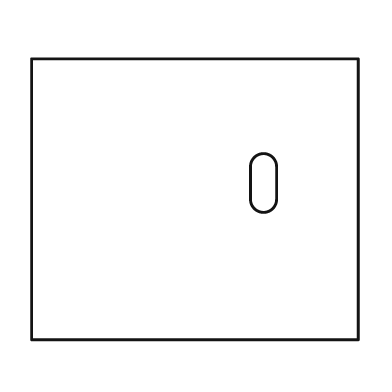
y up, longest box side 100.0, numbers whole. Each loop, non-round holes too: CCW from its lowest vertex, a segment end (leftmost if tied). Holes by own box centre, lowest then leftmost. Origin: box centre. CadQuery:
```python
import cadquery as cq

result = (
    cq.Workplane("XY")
    .moveTo(-50.0, -43.0)
    .lineTo(50.0, -43.0)
    .lineTo(50.0, 43.0)
    .lineTo(-50.0, 43.0)
    .close()
    .moveTo(17.0, 0.0)
    .threePointArc((21.0, -4.0), (25.0, 0.0))
    .lineTo(25.0, 10.0)
    .threePointArc((21.0, 14.0), (17.0, 10.0))
    .close()
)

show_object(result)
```